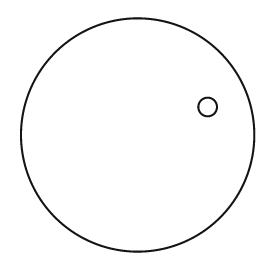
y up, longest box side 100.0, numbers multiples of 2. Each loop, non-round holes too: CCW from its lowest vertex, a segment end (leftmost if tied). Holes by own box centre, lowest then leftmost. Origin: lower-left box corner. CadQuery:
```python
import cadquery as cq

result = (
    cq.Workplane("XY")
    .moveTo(50.0, 50.0)
    .circle(50.0)
    .moveTo(80.0, 62.0)
    .circle(4.0)
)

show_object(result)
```